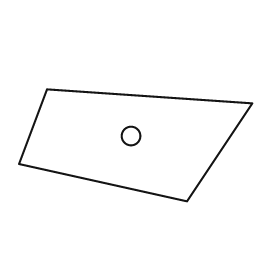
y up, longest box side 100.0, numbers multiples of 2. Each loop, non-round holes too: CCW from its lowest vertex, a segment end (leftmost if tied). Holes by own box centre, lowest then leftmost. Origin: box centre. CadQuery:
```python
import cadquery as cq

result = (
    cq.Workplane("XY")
    .moveTo(22.0, -24.0)
    .lineTo(50.0, 18.0)
    .lineTo(-38.0, 24.0)
    .lineTo(-50.0, -8.0)
    .close()
    .moveTo(-2.0, 4.0)
    .circle(4.0)
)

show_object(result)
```